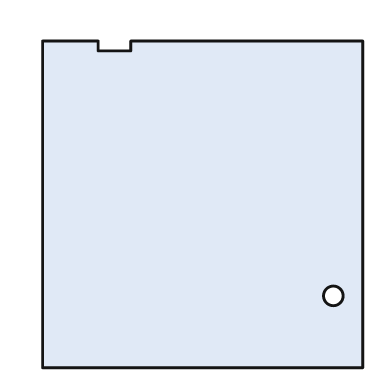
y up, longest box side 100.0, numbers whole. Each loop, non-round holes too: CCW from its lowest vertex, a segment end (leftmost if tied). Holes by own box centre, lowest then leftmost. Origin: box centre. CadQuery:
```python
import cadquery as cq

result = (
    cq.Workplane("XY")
    .moveTo(-49.0, -50.0)
    .lineTo(49.0, -50.0)
    .lineTo(49.0, 50.0)
    .lineTo(-22.0, 50.0)
    .lineTo(-22.0, 47.0)
    .lineTo(-32.0, 47.0)
    .lineTo(-32.0, 50.0)
    .lineTo(-49.0, 50.0)
    .close()
    .moveTo(40.0, -28.0)
    .circle(3.0)
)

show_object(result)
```